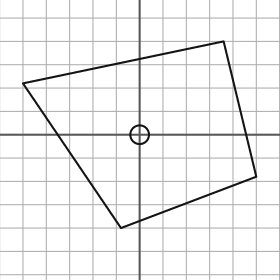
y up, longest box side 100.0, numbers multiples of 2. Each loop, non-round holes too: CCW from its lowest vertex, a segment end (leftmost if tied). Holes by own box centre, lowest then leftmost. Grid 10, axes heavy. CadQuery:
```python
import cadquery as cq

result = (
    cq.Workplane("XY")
    .moveTo(-8.0, -40.0)
    .lineTo(50.0, -18.0)
    .lineTo(36.0, 40.0)
    .lineTo(-50.0, 22.0)
    .close()
    .moveTo(0.0, 0.0)
    .circle(4.0)
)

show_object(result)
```